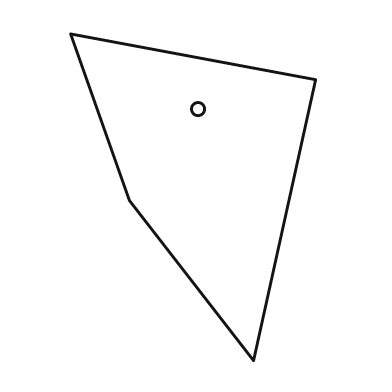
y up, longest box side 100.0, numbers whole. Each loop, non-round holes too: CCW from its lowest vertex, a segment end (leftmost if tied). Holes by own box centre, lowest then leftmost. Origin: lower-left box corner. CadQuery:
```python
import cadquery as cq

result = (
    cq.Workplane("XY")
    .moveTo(56.0, 0.0)
    .lineTo(75.0, 86.0)
    .lineTo(0.0, 100.0)
    .lineTo(18.0, 49.0)
    .close()
    .moveTo(39.0, 77.0)
    .circle(2.0)
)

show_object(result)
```